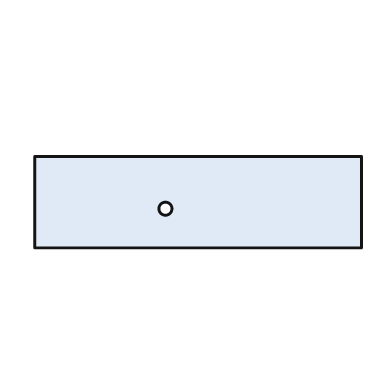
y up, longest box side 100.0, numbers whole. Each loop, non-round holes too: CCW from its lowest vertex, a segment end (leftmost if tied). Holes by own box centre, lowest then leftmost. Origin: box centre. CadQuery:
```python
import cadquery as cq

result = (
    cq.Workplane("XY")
    .moveTo(-50.0, -14.0)
    .lineTo(50.0, -14.0)
    .lineTo(50.0, 14.0)
    .lineTo(-50.0, 14.0)
    .close()
    .moveTo(-10.0, -2.0)
    .circle(2.0)
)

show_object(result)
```